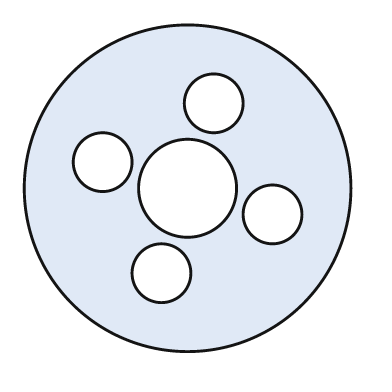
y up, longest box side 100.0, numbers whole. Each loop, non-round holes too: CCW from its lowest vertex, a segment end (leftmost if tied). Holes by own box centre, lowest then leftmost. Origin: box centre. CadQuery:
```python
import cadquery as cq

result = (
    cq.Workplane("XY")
    .moveTo(0.0, 0.0)
    .circle(50.0)
    .moveTo(-8.0, -26.0)
    .circle(9.0)
    .moveTo(26.0, -8.0)
    .circle(9.0)
    .moveTo(0.0, 0.0)
    .circle(15.0)
    .moveTo(-26.0, 8.0)
    .circle(9.0)
    .moveTo(8.0, 26.0)
    .circle(9.0)
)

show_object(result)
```